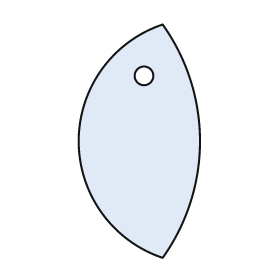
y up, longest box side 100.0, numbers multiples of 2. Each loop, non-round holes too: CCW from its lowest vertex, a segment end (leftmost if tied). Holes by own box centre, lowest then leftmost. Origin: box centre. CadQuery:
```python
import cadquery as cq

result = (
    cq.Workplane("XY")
    .moveTo(10.0, -50.0)
    .threePointArc((26.0, 0.0), (10.0, 50.0))
    .threePointArc((-26.0, 0.0), (10.0, -50.0))
    .close()
    .moveTo(2.0, 28.0)
    .circle(4.0)
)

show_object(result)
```